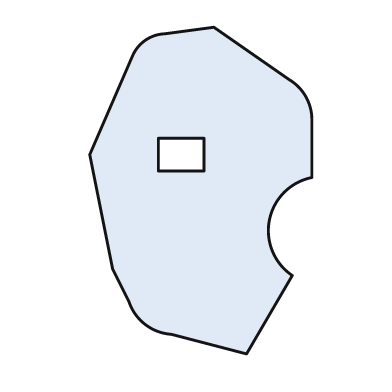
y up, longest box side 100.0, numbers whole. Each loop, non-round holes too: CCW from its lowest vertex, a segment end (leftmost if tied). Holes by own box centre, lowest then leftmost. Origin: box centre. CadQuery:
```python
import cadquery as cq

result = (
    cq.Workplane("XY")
    .moveTo(14.0, -50.0)
    .lineTo(28.0, -26.0)
    .threePointArc((21.0, -9.0), (34.0, 4.0))
    .lineTo(34.0, 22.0)
    .threePointArc((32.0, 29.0), (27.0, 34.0))
    .lineTo(4.0, 50.0)
    .lineTo(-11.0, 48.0)
    .threePointArc((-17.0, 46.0), (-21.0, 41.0))
    .lineTo(-34.0, 11.0)
    .lineTo(-27.0, -24.0)
    .lineTo(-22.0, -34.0)
    .threePointArc((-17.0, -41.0), (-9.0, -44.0))
    .close()
    .moveTo(-13.0, 6.0)
    .lineTo(1.0, 6.0)
    .lineTo(1.0, 16.0)
    .lineTo(-13.0, 16.0)
    .close()
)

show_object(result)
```